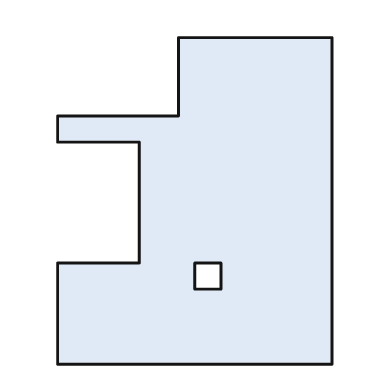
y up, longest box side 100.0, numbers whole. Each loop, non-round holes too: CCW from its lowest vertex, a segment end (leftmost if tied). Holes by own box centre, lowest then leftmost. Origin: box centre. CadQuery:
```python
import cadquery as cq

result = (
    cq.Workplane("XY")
    .moveTo(-42.0, -50.0)
    .lineTo(42.0, -50.0)
    .lineTo(42.0, 50.0)
    .lineTo(-5.0, 50.0)
    .lineTo(-5.0, 26.0)
    .lineTo(-42.0, 26.0)
    .lineTo(-42.0, 18.0)
    .lineTo(-17.0, 18.0)
    .lineTo(-17.0, -19.0)
    .lineTo(-42.0, -19.0)
    .close()
    .moveTo(0.0, -27.0)
    .lineTo(8.0, -27.0)
    .lineTo(8.0, -19.0)
    .lineTo(0.0, -19.0)
    .close()
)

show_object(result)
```